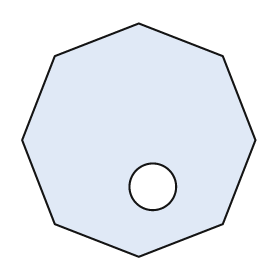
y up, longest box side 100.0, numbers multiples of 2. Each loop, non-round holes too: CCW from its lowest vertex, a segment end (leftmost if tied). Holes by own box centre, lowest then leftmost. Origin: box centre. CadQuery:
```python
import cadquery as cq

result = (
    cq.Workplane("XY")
    .moveTo(0.0, -50.0)
    .lineTo(36.0, -36.0)
    .lineTo(50.0, 0.0)
    .lineTo(36.0, 36.0)
    .lineTo(0.0, 50.0)
    .lineTo(-36.0, 36.0)
    .lineTo(-50.0, 0.0)
    .lineTo(-36.0, -36.0)
    .close()
    .moveTo(6.0, -20.0)
    .circle(10.0)
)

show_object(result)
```